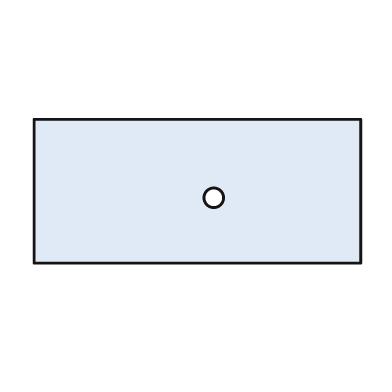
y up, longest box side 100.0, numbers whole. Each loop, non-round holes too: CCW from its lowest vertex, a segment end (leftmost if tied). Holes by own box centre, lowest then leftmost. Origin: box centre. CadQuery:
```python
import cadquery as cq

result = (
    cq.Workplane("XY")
    .moveTo(-50.0, -22.0)
    .lineTo(50.0, -22.0)
    .lineTo(50.0, 22.0)
    .lineTo(-50.0, 22.0)
    .close()
    .moveTo(5.0, -2.0)
    .circle(3.0)
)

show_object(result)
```